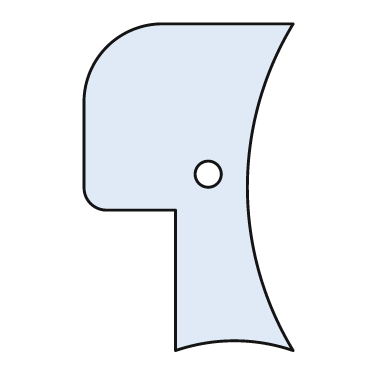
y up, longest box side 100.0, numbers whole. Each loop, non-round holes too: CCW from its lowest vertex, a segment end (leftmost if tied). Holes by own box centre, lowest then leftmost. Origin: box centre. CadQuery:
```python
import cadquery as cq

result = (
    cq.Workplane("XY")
    .moveTo(-4.0, -50.0)
    .threePointArc((14.0, -47.0), (32.0, -50.0))
    .threePointArc((18.0, 0.0), (32.0, 50.0))
    .lineTo(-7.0, 50.0)
    .threePointArc((-25.0, 43.0), (-32.0, 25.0))
    .lineTo(-32.0, 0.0)
    .threePointArc((-30.0, -5.0), (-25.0, -7.0))
    .lineTo(-4.0, -7.0)
    .close()
    .moveTo(6.0, 4.0)
    .circle(4.0)
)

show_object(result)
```